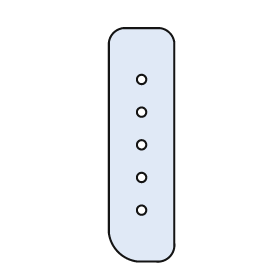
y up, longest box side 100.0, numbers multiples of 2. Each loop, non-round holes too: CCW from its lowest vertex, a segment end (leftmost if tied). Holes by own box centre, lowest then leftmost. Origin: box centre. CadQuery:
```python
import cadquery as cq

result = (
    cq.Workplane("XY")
    .moveTo(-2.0, -50.0)
    .lineTo(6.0, -50.0)
    .threePointArc((12.0, -48.0), (14.0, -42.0))
    .lineTo(14.0, 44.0)
    .threePointArc((12.0, 48.0), (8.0, 50.0))
    .lineTo(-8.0, 50.0)
    .threePointArc((-12.0, 48.0), (-14.0, 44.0))
    .lineTo(-14.0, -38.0)
    .threePointArc((-10.0, -46.0), (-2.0, -50.0))
    .close()
    .moveTo(0.0, -28.0)
    .circle(2.0)
    .moveTo(0.0, -14.0)
    .circle(2.0)
    .moveTo(0.0, 0.0)
    .circle(2.0)
    .moveTo(0.0, 14.0)
    .circle(2.0)
    .moveTo(0.0, 28.0)
    .circle(2.0)
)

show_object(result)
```